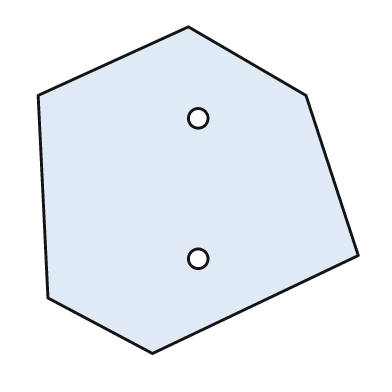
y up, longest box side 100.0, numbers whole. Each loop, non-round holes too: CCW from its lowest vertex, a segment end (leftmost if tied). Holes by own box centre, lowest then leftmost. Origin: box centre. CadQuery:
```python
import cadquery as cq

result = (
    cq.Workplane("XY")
    .moveTo(-14.0, -50.0)
    .lineTo(49.0, -20.0)
    .lineTo(33.0, 29.0)
    .lineTo(-3.0, 50.0)
    .lineTo(-49.0, 29.0)
    .lineTo(-46.0, -33.0)
    .close()
    .moveTo(0.0, -21.0)
    .circle(3.0)
    .moveTo(0.0, 22.0)
    .circle(3.0)
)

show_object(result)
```